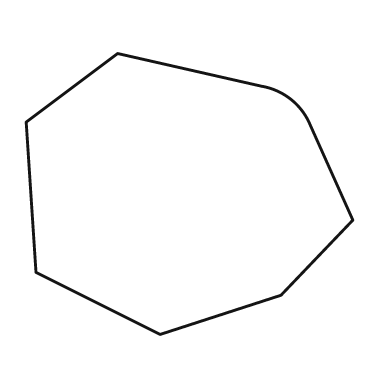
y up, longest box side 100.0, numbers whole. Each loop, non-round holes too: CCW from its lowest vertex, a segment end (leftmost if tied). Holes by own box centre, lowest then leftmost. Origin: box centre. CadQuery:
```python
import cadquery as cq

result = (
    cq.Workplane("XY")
    .moveTo(-9.0, -43.0)
    .lineTo(28.0, -31.0)
    .lineTo(50.0, -8.0)
    .lineTo(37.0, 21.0)
    .threePointArc((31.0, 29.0), (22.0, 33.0))
    .lineTo(-22.0, 43.0)
    .lineTo(-50.0, 22.0)
    .lineTo(-47.0, -24.0)
    .close()
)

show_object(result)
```